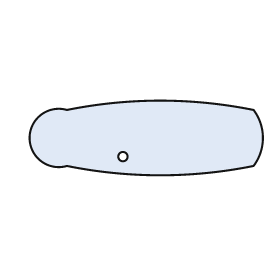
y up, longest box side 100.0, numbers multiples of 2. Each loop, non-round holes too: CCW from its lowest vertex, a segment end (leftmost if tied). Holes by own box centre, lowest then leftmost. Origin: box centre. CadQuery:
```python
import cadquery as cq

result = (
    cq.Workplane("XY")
    .moveTo(-34.0, -12.0)
    .threePointArc((6.0, -16.0), (46.0, -12.0))
    .threePointArc((50.0, 0.0), (46.0, 12.0))
    .threePointArc((6.0, 16.0), (-34.0, 12.0))
    .threePointArc((-50.0, 0.0), (-34.0, -12.0))
    .close()
    .moveTo(-10.0, -8.0)
    .circle(2.0)
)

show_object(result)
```